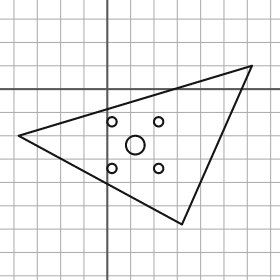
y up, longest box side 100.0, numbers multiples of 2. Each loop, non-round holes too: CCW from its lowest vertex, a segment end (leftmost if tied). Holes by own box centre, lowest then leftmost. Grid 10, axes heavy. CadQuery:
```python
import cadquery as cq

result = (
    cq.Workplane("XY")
    .moveTo(32.0, -58.0)
    .lineTo(62.0, 10.0)
    .lineTo(-38.0, -20.0)
    .close()
    .moveTo(2.0, -34.0)
    .circle(2.0)
    .moveTo(22.0, -34.0)
    .circle(2.0)
    .moveTo(12.0, -24.0)
    .circle(4.0)
    .moveTo(2.0, -14.0)
    .circle(2.0)
    .moveTo(22.0, -14.0)
    .circle(2.0)
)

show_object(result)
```